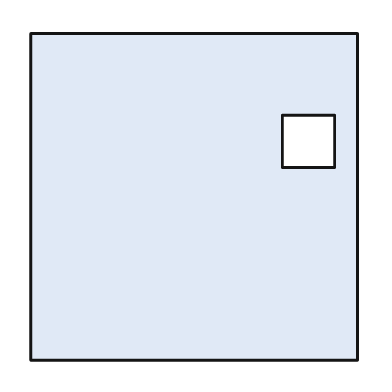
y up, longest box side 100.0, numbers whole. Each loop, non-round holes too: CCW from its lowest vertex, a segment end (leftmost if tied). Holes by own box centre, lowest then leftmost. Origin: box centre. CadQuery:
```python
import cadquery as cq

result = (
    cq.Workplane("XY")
    .moveTo(-50.0, -50.0)
    .lineTo(50.0, -50.0)
    .lineTo(50.0, 50.0)
    .lineTo(-50.0, 50.0)
    .close()
    .moveTo(27.0, 9.0)
    .lineTo(43.0, 9.0)
    .lineTo(43.0, 25.0)
    .lineTo(27.0, 25.0)
    .close()
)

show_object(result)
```